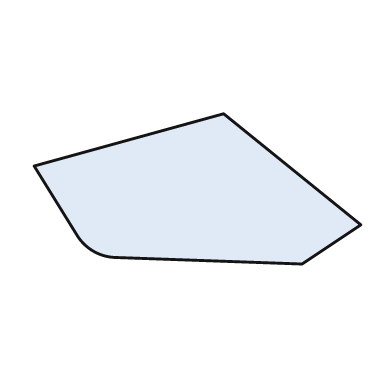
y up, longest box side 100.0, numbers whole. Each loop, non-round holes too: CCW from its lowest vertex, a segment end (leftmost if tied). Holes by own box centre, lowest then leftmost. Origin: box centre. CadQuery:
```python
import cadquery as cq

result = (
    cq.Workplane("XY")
    .moveTo(32.0, -23.0)
    .lineTo(50.0, -11.0)
    .lineTo(8.0, 23.0)
    .lineTo(-50.0, 7.0)
    .lineTo(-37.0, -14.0)
    .threePointArc((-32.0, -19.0), (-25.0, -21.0))
    .close()
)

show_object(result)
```